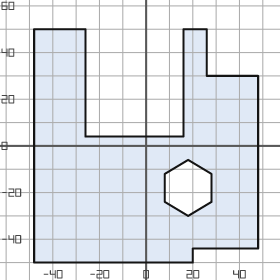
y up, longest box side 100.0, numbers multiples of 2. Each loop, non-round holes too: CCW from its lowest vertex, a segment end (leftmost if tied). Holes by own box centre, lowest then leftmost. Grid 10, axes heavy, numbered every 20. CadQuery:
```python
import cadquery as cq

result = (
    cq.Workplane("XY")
    .moveTo(-48.0, -50.0)
    .lineTo(20.0, -50.0)
    .lineTo(20.0, -44.0)
    .lineTo(48.0, -44.0)
    .lineTo(48.0, 30.0)
    .lineTo(26.0, 30.0)
    .lineTo(26.0, 50.0)
    .lineTo(16.0, 50.0)
    .lineTo(16.0, 4.0)
    .lineTo(-26.0, 4.0)
    .lineTo(-26.0, 50.0)
    .lineTo(-48.0, 50.0)
    .close()
    .moveTo(18.0, -30.0)
    .lineTo(28.0, -24.0)
    .lineTo(28.0, -12.0)
    .lineTo(18.0, -6.0)
    .lineTo(8.0, -12.0)
    .lineTo(8.0, -24.0)
    .close()
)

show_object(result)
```